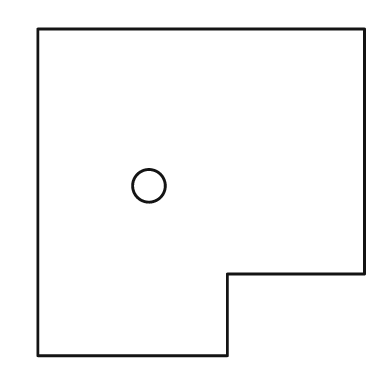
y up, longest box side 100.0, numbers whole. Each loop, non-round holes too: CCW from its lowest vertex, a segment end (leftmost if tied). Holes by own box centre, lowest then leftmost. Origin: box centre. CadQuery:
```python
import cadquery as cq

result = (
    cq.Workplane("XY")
    .moveTo(-50.0, -50.0)
    .lineTo(8.0, -50.0)
    .lineTo(8.0, -25.0)
    .lineTo(50.0, -25.0)
    .lineTo(50.0, 50.0)
    .lineTo(-50.0, 50.0)
    .close()
    .moveTo(-16.0, 2.0)
    .circle(5.0)
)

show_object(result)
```